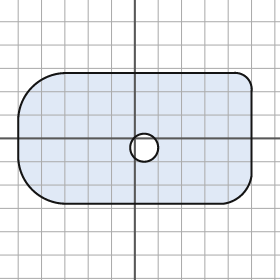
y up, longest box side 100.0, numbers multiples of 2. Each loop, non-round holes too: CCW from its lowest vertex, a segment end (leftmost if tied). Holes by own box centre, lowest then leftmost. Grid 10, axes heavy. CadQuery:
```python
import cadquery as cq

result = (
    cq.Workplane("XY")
    .moveTo(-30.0, -28.0)
    .lineTo(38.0, -28.0)
    .threePointArc((46.0, -24.0), (50.0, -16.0))
    .lineTo(50.0, 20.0)
    .threePointArc((48.0, 26.0), (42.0, 28.0))
    .lineTo(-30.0, 28.0)
    .threePointArc((-44.0, 22.0), (-50.0, 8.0))
    .lineTo(-50.0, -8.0)
    .threePointArc((-44.0, -22.0), (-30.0, -28.0))
    .close()
    .moveTo(4.0, -4.0)
    .circle(6.0)
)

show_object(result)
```